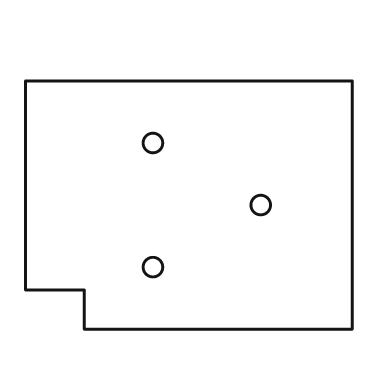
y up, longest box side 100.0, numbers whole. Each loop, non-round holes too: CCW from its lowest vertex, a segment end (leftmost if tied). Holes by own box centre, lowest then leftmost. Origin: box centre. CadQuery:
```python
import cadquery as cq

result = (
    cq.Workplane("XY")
    .moveTo(-32.0, -38.0)
    .lineTo(50.0, -38.0)
    .lineTo(50.0, 38.0)
    .lineTo(-50.0, 38.0)
    .lineTo(-50.0, -26.0)
    .lineTo(-32.0, -26.0)
    .close()
    .moveTo(-11.0, -19.0)
    .circle(3.0)
    .moveTo(22.0, 0.0)
    .circle(3.0)
    .moveTo(-11.0, 19.0)
    .circle(3.0)
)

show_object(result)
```